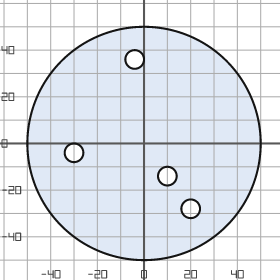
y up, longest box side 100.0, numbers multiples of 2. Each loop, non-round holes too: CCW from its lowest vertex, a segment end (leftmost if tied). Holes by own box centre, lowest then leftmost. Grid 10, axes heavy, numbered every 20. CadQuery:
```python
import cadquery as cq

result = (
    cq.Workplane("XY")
    .moveTo(0.0, 0.0)
    .circle(50.0)
    .moveTo(20.0, -28.0)
    .circle(4.0)
    .moveTo(10.0, -14.0)
    .circle(4.0)
    .moveTo(-30.0, -4.0)
    .circle(4.0)
    .moveTo(-4.0, 36.0)
    .circle(4.0)
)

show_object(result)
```